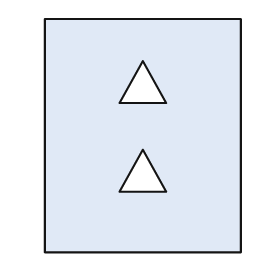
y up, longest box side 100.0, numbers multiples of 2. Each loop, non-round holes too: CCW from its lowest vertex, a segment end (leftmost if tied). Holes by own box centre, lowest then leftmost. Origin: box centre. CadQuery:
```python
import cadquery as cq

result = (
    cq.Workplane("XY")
    .moveTo(-42.0, -50.0)
    .lineTo(42.0, -50.0)
    .lineTo(42.0, 50.0)
    .lineTo(-42.0, 50.0)
    .close()
    .moveTo(-10.0, -24.0)
    .lineTo(10.0, -24.0)
    .lineTo(0.0, -6.0)
    .close()
    .moveTo(-10.0, 14.0)
    .lineTo(10.0, 14.0)
    .lineTo(0.0, 32.0)
    .close()
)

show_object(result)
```